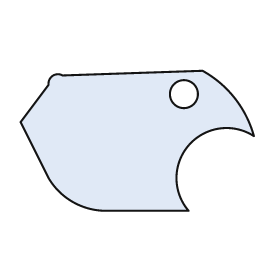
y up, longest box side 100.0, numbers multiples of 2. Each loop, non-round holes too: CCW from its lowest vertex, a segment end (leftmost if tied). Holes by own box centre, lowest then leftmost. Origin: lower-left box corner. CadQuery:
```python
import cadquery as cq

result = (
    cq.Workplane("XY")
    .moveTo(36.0, 0.0)
    .lineTo(72.0, 0.0)
    .threePointArc((72.0, 28.0), (100.0, 32.0))
    .threePointArc((92.0, 48.0), (78.0, 60.0))
    .lineTo(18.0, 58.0)
    .threePointArc((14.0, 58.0), (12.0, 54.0))
    .lineTo(0.0, 38.0)
    .lineTo(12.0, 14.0)
    .threePointArc((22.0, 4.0), (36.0, 0.0))
    .close()
    .moveTo(70.0, 50.0)
    .circle(6.0)
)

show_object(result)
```